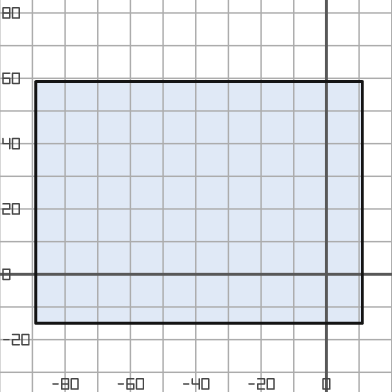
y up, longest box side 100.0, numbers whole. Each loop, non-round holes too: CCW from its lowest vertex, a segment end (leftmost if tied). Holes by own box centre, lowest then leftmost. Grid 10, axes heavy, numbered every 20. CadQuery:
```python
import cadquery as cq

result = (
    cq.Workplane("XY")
    .moveTo(-89.0, -15.0)
    .lineTo(11.0, -15.0)
    .lineTo(11.0, 59.0)
    .lineTo(-89.0, 59.0)
    .close()
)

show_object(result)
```